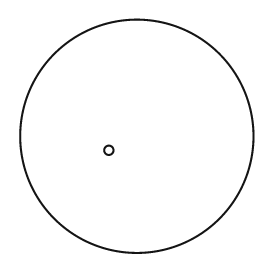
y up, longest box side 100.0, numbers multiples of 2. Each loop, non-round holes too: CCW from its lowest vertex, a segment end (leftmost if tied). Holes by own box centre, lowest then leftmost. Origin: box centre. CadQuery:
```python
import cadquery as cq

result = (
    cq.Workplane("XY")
    .moveTo(0.0, 0.0)
    .circle(50.0)
    .moveTo(-12.0, -6.0)
    .circle(2.0)
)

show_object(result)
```